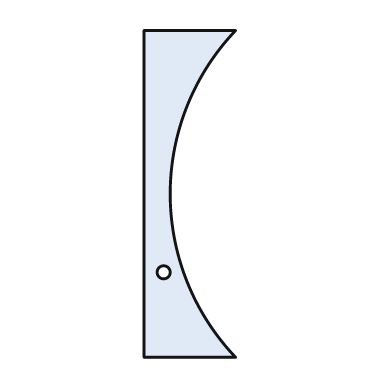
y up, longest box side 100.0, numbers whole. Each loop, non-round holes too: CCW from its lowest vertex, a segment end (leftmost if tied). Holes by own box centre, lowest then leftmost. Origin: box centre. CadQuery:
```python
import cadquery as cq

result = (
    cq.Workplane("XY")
    .moveTo(-14.0, -50.0)
    .lineTo(14.0, -50.0)
    .threePointArc((-6.0, 0.0), (14.0, 50.0))
    .lineTo(-14.0, 50.0)
    .close()
    .moveTo(-8.0, -24.0)
    .circle(2.0)
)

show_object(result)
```